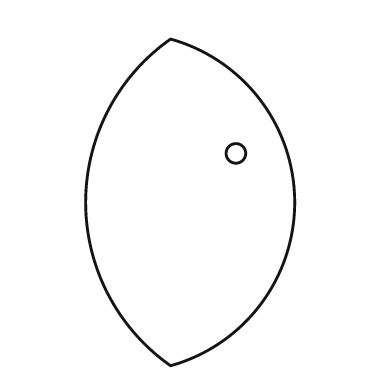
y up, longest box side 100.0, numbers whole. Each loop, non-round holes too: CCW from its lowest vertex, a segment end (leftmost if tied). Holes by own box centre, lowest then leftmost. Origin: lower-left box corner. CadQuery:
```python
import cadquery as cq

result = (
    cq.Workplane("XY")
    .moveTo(26.0, 0.0)
    .threePointArc((64.0, 50.0), (26.0, 100.0))
    .threePointArc((0.0, 50.0), (26.0, 0.0))
    .close()
    .moveTo(46.0, 65.0)
    .circle(3.0)
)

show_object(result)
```